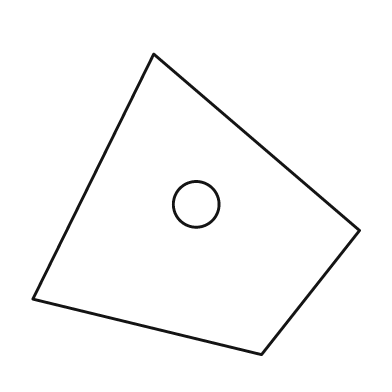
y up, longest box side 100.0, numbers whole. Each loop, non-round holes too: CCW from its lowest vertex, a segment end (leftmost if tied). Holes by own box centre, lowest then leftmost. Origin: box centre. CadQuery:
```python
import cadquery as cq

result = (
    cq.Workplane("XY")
    .moveTo(20.0, -46.0)
    .lineTo(50.0, -8.0)
    .lineTo(-13.0, 46.0)
    .lineTo(-50.0, -29.0)
    .close()
    .moveTo(0.0, 0.0)
    .circle(7.0)
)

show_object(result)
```